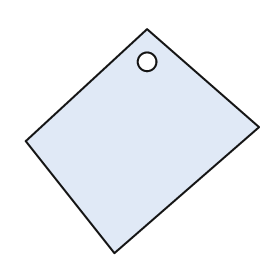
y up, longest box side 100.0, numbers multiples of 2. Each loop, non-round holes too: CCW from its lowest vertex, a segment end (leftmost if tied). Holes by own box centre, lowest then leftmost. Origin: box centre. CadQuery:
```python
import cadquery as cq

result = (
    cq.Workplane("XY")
    .moveTo(-12.0, -48.0)
    .lineTo(50.0, 6.0)
    .lineTo(2.0, 48.0)
    .lineTo(-50.0, 0.0)
    .close()
    .moveTo(2.0, 34.0)
    .circle(4.0)
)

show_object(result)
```